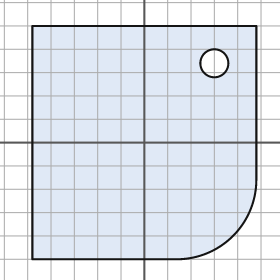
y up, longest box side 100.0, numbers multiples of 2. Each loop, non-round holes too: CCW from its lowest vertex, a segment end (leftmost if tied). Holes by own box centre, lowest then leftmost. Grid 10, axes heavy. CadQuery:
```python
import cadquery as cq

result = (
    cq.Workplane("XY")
    .moveTo(-48.0, -50.0)
    .lineTo(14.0, -50.0)
    .threePointArc((38.0, -40.0), (48.0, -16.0))
    .lineTo(48.0, 50.0)
    .lineTo(-48.0, 50.0)
    .close()
    .moveTo(30.0, 34.0)
    .circle(6.0)
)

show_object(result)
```